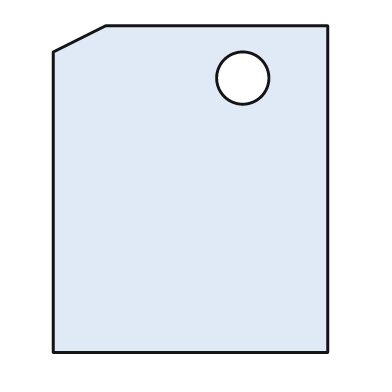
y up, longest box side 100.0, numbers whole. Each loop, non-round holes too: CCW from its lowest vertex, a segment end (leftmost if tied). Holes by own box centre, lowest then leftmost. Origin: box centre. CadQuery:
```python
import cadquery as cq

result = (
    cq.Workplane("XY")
    .moveTo(-42.0, -50.0)
    .lineTo(42.0, -50.0)
    .lineTo(42.0, 50.0)
    .lineTo(-26.0, 50.0)
    .lineTo(-42.0, 42.0)
    .close()
    .moveTo(16.0, 34.0)
    .circle(8.0)
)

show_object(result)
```